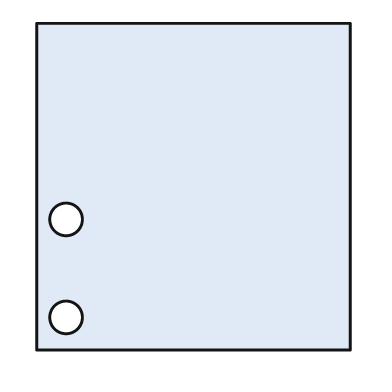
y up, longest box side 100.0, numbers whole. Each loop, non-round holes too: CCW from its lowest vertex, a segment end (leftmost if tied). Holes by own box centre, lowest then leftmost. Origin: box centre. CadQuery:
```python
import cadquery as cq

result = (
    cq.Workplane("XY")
    .moveTo(-48.0, -50.0)
    .lineTo(48.0, -50.0)
    .lineTo(48.0, 50.0)
    .lineTo(-48.0, 50.0)
    .close()
    .moveTo(-39.0, -40.0)
    .circle(5.0)
    .moveTo(-39.0, -10.0)
    .circle(5.0)
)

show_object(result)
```